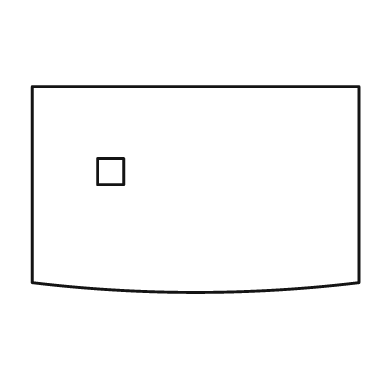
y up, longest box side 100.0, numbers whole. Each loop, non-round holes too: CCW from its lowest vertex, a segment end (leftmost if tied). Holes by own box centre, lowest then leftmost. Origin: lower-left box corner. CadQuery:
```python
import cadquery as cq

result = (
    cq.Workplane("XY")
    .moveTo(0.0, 3.0)
    .threePointArc((50.0, 0.0), (100.0, 3.0))
    .lineTo(100.0, 63.0)
    .lineTo(0.0, 63.0)
    .close()
    .moveTo(20.0, 33.0)
    .lineTo(28.0, 33.0)
    .lineTo(28.0, 41.0)
    .lineTo(20.0, 41.0)
    .close()
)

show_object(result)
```